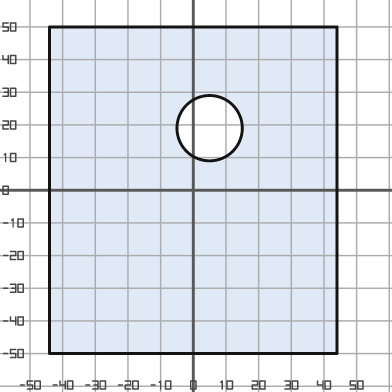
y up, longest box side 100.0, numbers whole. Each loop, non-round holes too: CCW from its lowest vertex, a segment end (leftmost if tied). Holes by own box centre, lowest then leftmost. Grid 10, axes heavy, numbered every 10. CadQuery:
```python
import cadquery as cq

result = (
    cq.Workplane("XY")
    .moveTo(-44.0, -50.0)
    .lineTo(44.0, -50.0)
    .lineTo(44.0, 50.0)
    .lineTo(-44.0, 50.0)
    .close()
    .moveTo(5.0, 19.0)
    .circle(10.0)
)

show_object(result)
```